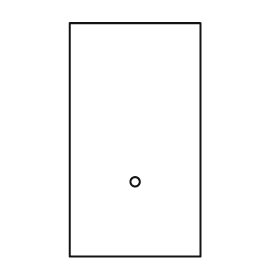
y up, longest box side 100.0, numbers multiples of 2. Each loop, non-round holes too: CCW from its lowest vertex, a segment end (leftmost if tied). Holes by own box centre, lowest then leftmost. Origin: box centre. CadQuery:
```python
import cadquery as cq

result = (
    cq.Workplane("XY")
    .moveTo(-28.0, -50.0)
    .lineTo(28.0, -50.0)
    .lineTo(28.0, 50.0)
    .lineTo(-28.0, 50.0)
    .close()
    .moveTo(0.0, -18.0)
    .circle(2.0)
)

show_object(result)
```